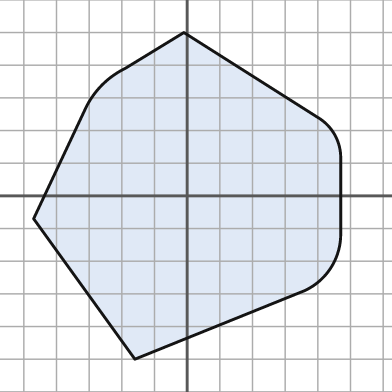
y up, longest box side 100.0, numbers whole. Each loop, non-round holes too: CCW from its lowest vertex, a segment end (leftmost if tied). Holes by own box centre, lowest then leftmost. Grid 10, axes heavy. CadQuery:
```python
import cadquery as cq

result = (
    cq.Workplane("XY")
    .moveTo(-16.0, -50.0)
    .lineTo(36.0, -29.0)
    .threePointArc((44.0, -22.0), (47.0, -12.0))
    .lineTo(47.0, 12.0)
    .threePointArc((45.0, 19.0), (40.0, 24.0))
    .lineTo(-1.0, 50.0)
    .lineTo(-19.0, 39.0)
    .threePointArc((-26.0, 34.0), (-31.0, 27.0))
    .lineTo(-47.0, -7.0)
    .close()
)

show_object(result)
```